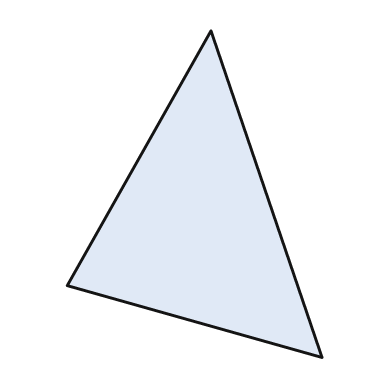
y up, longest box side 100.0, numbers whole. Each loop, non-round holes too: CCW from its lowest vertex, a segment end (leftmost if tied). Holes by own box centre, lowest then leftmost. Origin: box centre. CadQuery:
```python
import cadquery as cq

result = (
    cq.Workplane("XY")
    .moveTo(39.0, -50.0)
    .lineTo(5.0, 50.0)
    .lineTo(-39.0, -28.0)
    .close()
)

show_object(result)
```